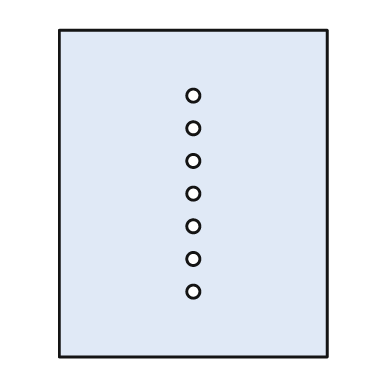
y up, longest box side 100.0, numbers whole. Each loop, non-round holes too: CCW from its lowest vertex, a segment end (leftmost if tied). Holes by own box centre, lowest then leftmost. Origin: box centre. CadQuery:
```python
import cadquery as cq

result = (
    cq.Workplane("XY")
    .moveTo(-41.0, -50.0)
    .lineTo(41.0, -50.0)
    .lineTo(41.0, 50.0)
    .lineTo(-41.0, 50.0)
    .close()
    .moveTo(0.0, -30.0)
    .circle(2.0)
    .moveTo(0.0, -20.0)
    .circle(2.0)
    .moveTo(0.0, -10.0)
    .circle(2.0)
    .moveTo(0.0, 0.0)
    .circle(2.0)
    .moveTo(0.0, 10.0)
    .circle(2.0)
    .moveTo(0.0, 20.0)
    .circle(2.0)
    .moveTo(0.0, 30.0)
    .circle(2.0)
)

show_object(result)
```